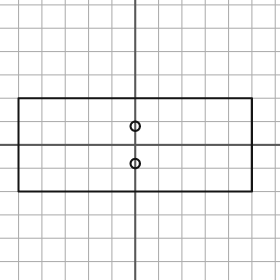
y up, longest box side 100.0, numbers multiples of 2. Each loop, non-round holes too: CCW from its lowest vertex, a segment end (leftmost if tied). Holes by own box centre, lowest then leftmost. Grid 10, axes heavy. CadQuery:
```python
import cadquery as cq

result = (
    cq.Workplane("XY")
    .moveTo(-50.0, -20.0)
    .lineTo(50.0, -20.0)
    .lineTo(50.0, 20.0)
    .lineTo(-50.0, 20.0)
    .close()
    .moveTo(0.0, -8.0)
    .circle(2.0)
    .moveTo(0.0, 8.0)
    .circle(2.0)
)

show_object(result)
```